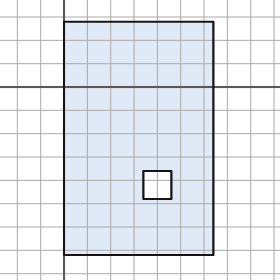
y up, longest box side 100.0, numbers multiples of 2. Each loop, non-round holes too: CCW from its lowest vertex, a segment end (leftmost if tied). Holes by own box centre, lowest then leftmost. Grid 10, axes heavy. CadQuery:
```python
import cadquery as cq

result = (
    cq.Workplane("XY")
    .moveTo(0.0, -72.0)
    .lineTo(64.0, -72.0)
    .lineTo(64.0, 28.0)
    .lineTo(0.0, 28.0)
    .close()
    .moveTo(34.0, -48.0)
    .lineTo(46.0, -48.0)
    .lineTo(46.0, -36.0)
    .lineTo(34.0, -36.0)
    .close()
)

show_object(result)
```